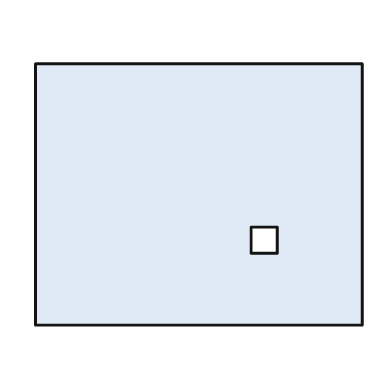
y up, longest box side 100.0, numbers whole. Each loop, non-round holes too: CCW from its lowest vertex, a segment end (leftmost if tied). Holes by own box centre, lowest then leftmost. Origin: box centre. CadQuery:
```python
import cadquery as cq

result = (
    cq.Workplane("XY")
    .moveTo(-50.0, -40.0)
    .lineTo(50.0, -40.0)
    .lineTo(50.0, 40.0)
    .lineTo(-50.0, 40.0)
    .close()
    .moveTo(16.0, -18.0)
    .lineTo(24.0, -18.0)
    .lineTo(24.0, -10.0)
    .lineTo(16.0, -10.0)
    .close()
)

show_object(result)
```